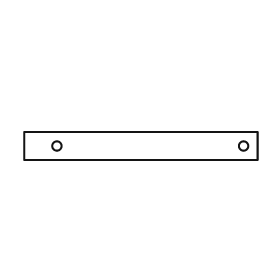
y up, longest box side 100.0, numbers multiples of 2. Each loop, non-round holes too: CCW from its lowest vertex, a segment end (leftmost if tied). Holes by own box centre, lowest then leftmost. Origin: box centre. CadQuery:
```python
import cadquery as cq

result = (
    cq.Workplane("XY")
    .moveTo(-50.0, -6.0)
    .lineTo(50.0, -6.0)
    .lineTo(50.0, 6.0)
    .lineTo(-50.0, 6.0)
    .close()
    .moveTo(-36.0, 0.0)
    .circle(2.0)
    .moveTo(44.0, 0.0)
    .circle(2.0)
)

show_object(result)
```